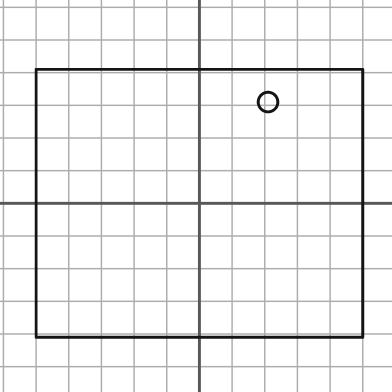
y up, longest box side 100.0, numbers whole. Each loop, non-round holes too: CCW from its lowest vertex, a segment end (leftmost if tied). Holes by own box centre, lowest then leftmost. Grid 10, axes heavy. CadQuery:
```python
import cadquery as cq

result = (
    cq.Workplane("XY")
    .moveTo(-50.0, -41.0)
    .lineTo(50.0, -41.0)
    .lineTo(50.0, 41.0)
    .lineTo(-50.0, 41.0)
    .close()
    .moveTo(21.0, 31.0)
    .circle(3.0)
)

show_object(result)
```